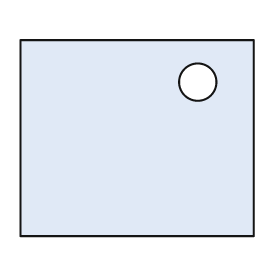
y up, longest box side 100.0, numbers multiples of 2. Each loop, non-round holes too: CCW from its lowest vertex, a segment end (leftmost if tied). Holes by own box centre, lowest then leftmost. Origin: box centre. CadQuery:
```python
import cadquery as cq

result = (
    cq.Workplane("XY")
    .moveTo(-50.0, -42.0)
    .lineTo(50.0, -42.0)
    .lineTo(50.0, 42.0)
    .lineTo(-50.0, 42.0)
    .close()
    .moveTo(26.0, 24.0)
    .circle(8.0)
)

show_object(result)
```